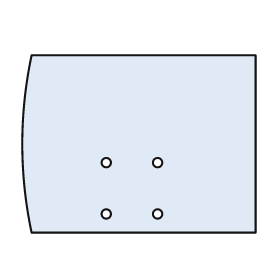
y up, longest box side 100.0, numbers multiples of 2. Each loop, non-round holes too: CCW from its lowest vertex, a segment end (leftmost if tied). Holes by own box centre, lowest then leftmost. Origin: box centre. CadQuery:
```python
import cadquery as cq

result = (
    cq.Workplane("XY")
    .moveTo(-46.0, -38.0)
    .lineTo(50.0, -38.0)
    .lineTo(50.0, 38.0)
    .lineTo(-46.0, 38.0)
    .threePointArc((-50.0, 0.0), (-46.0, -38.0))
    .close()
    .moveTo(-14.0, -30.0)
    .circle(2.0)
    .moveTo(8.0, -30.0)
    .circle(2.0)
    .moveTo(-14.0, -8.0)
    .circle(2.0)
    .moveTo(8.0, -8.0)
    .circle(2.0)
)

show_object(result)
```